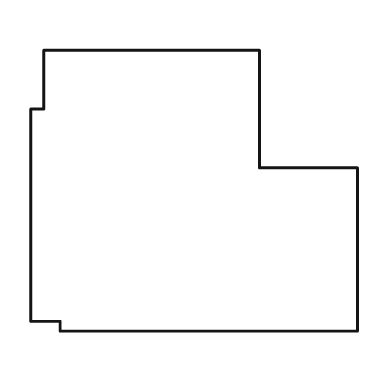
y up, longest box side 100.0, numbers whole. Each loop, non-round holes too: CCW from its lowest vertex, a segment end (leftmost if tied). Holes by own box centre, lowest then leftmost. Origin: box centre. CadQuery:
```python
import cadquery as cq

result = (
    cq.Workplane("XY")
    .moveTo(-41.0, -43.0)
    .lineTo(50.0, -43.0)
    .lineTo(50.0, 7.0)
    .lineTo(20.0, 7.0)
    .lineTo(20.0, 43.0)
    .lineTo(-46.0, 43.0)
    .lineTo(-46.0, 25.0)
    .lineTo(-50.0, 25.0)
    .lineTo(-50.0, -40.0)
    .lineTo(-41.0, -40.0)
    .close()
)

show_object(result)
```